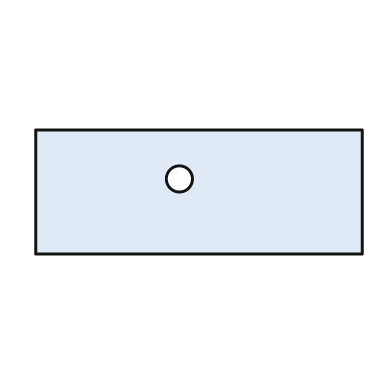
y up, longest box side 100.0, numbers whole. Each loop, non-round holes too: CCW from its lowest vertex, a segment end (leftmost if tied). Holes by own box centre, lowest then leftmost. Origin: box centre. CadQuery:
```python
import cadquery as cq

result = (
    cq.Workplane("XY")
    .moveTo(-50.0, -19.0)
    .lineTo(50.0, -19.0)
    .lineTo(50.0, 19.0)
    .lineTo(-50.0, 19.0)
    .close()
    .moveTo(-6.0, 4.0)
    .circle(4.0)
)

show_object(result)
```